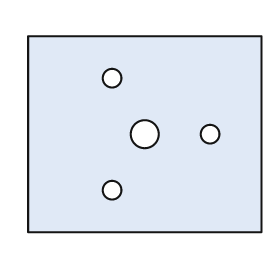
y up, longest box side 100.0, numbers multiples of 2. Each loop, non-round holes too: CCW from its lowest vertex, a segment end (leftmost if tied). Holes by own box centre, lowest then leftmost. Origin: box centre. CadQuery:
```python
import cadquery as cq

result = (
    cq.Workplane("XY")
    .moveTo(-50.0, -42.0)
    .lineTo(50.0, -42.0)
    .lineTo(50.0, 42.0)
    .lineTo(-50.0, 42.0)
    .close()
    .moveTo(-14.0, -24.0)
    .circle(4.0)
    .moveTo(0.0, 0.0)
    .circle(6.0)
    .moveTo(28.0, 0.0)
    .circle(4.0)
    .moveTo(-14.0, 24.0)
    .circle(4.0)
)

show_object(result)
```